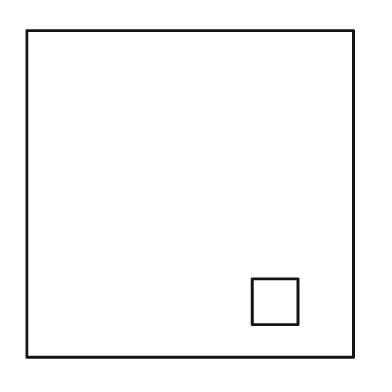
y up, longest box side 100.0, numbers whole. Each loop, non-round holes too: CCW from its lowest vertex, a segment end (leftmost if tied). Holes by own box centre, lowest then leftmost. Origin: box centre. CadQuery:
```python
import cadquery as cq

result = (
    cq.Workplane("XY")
    .moveTo(-50.0, -50.0)
    .lineTo(50.0, -50.0)
    .lineTo(50.0, 50.0)
    .lineTo(-50.0, 50.0)
    .close()
    .moveTo(19.0, -40.0)
    .lineTo(33.0, -40.0)
    .lineTo(33.0, -26.0)
    .lineTo(19.0, -26.0)
    .close()
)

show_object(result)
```